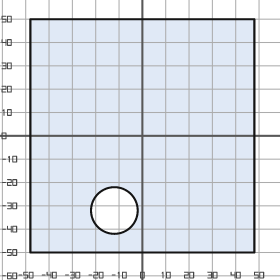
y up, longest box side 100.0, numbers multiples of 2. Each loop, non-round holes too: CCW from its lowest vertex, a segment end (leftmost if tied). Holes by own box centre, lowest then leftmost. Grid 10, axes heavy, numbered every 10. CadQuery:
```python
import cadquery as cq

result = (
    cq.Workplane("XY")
    .moveTo(-48.0, -50.0)
    .lineTo(48.0, -50.0)
    .lineTo(48.0, 50.0)
    .lineTo(-48.0, 50.0)
    .close()
    .moveTo(-12.0, -32.0)
    .circle(10.0)
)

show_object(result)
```